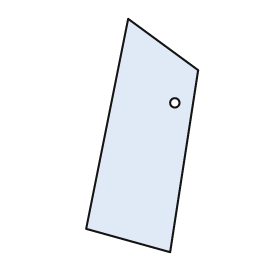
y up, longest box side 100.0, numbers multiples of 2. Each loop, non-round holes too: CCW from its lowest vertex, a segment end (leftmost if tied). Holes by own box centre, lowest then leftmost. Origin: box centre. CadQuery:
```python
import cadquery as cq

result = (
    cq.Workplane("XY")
    .moveTo(12.0, -50.0)
    .lineTo(24.0, 28.0)
    .lineTo(-6.0, 50.0)
    .lineTo(-24.0, -40.0)
    .close()
    .moveTo(14.0, 14.0)
    .circle(2.0)
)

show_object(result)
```